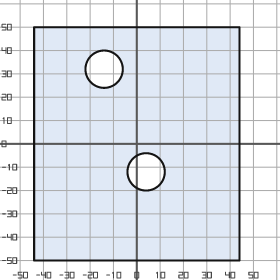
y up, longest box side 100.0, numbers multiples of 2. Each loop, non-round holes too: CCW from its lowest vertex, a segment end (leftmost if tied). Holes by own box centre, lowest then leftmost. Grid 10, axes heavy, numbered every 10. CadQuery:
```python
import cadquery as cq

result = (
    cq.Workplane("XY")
    .moveTo(-44.0, -50.0)
    .lineTo(44.0, -50.0)
    .lineTo(44.0, 50.0)
    .lineTo(-44.0, 50.0)
    .close()
    .moveTo(4.0, -12.0)
    .circle(8.0)
    .moveTo(-14.0, 32.0)
    .circle(8.0)
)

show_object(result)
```